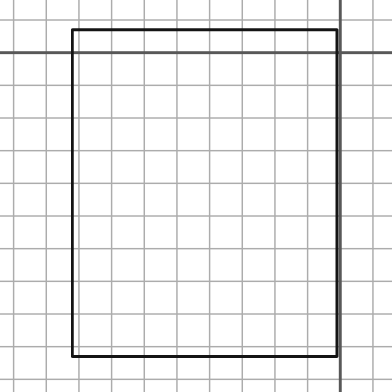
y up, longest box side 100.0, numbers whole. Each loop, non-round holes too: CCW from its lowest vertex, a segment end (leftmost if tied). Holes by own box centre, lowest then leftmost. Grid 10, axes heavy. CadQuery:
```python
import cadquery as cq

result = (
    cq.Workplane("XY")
    .moveTo(-82.0, -93.0)
    .lineTo(-1.0, -93.0)
    .lineTo(-1.0, 7.0)
    .lineTo(-82.0, 7.0)
    .close()
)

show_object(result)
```